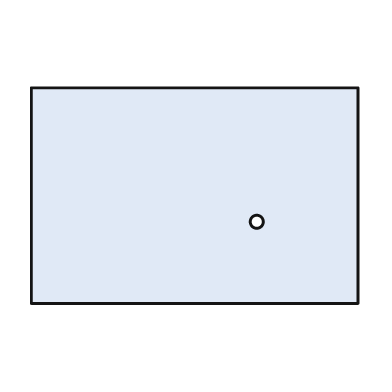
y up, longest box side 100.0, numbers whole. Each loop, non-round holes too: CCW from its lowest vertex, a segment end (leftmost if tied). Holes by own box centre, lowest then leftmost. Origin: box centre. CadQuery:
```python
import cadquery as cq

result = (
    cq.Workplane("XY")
    .moveTo(-50.0, -33.0)
    .lineTo(50.0, -33.0)
    .lineTo(50.0, 33.0)
    .lineTo(-50.0, 33.0)
    .close()
    .moveTo(19.0, -8.0)
    .circle(2.0)
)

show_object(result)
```